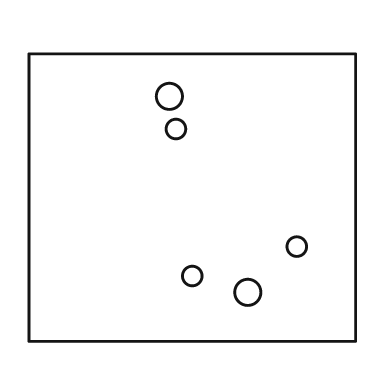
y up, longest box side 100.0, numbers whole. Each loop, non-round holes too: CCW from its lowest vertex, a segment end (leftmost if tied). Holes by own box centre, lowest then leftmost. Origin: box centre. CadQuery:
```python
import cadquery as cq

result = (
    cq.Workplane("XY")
    .moveTo(-50.0, -44.0)
    .lineTo(50.0, -44.0)
    .lineTo(50.0, 44.0)
    .lineTo(-50.0, 44.0)
    .close()
    .moveTo(17.0, -29.0)
    .circle(4.0)
    .moveTo(0.0, -24.0)
    .circle(3.0)
    .moveTo(32.0, -15.0)
    .circle(3.0)
    .moveTo(-5.0, 21.0)
    .circle(3.0)
    .moveTo(-7.0, 31.0)
    .circle(4.0)
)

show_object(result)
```